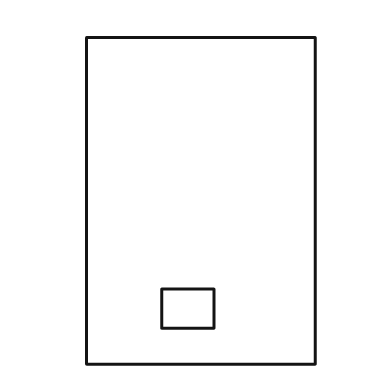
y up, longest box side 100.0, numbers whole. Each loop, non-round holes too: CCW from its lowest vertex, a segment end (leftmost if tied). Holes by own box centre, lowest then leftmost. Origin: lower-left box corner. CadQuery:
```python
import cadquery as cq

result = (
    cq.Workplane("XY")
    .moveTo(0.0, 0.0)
    .lineTo(70.0, 0.0)
    .lineTo(70.0, 100.0)
    .lineTo(0.0, 100.0)
    .close()
    .moveTo(23.0, 11.0)
    .lineTo(39.0, 11.0)
    .lineTo(39.0, 23.0)
    .lineTo(23.0, 23.0)
    .close()
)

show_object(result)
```